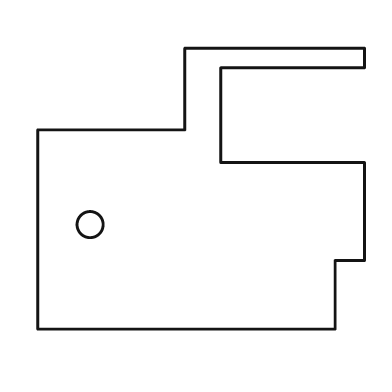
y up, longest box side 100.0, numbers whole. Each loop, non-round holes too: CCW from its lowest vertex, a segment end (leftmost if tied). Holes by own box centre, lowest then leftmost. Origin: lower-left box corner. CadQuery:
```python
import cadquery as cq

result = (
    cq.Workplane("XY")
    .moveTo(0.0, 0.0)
    .lineTo(91.0, 0.0)
    .lineTo(91.0, 21.0)
    .lineTo(100.0, 21.0)
    .lineTo(100.0, 51.0)
    .lineTo(56.0, 51.0)
    .lineTo(56.0, 80.0)
    .lineTo(100.0, 80.0)
    .lineTo(100.0, 86.0)
    .lineTo(45.0, 86.0)
    .lineTo(45.0, 61.0)
    .lineTo(0.0, 61.0)
    .close()
    .moveTo(16.0, 32.0)
    .circle(4.0)
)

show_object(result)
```